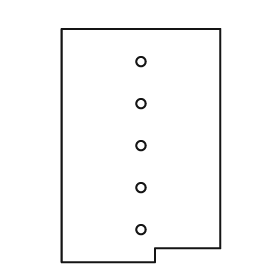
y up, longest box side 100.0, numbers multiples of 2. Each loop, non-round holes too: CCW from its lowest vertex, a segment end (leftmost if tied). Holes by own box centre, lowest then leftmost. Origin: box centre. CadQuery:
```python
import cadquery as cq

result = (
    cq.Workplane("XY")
    .moveTo(-34.0, -50.0)
    .lineTo(6.0, -50.0)
    .lineTo(6.0, -44.0)
    .lineTo(34.0, -44.0)
    .lineTo(34.0, 50.0)
    .lineTo(-34.0, 50.0)
    .close()
    .moveTo(0.0, -36.0)
    .circle(2.0)
    .moveTo(0.0, -18.0)
    .circle(2.0)
    .moveTo(0.0, 0.0)
    .circle(2.0)
    .moveTo(0.0, 18.0)
    .circle(2.0)
    .moveTo(0.0, 36.0)
    .circle(2.0)
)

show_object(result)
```